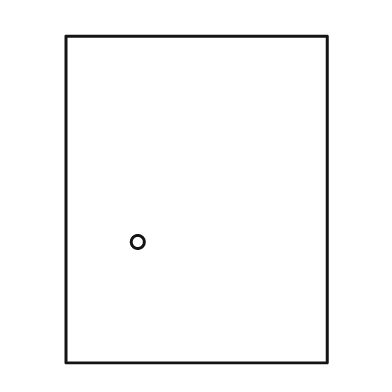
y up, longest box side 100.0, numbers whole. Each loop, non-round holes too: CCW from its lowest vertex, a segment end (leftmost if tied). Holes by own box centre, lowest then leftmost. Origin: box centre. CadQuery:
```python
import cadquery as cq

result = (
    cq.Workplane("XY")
    .moveTo(-40.0, -50.0)
    .lineTo(40.0, -50.0)
    .lineTo(40.0, 50.0)
    .lineTo(-40.0, 50.0)
    .close()
    .moveTo(-18.0, -13.0)
    .circle(2.0)
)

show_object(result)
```